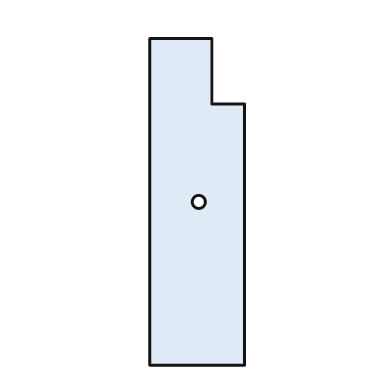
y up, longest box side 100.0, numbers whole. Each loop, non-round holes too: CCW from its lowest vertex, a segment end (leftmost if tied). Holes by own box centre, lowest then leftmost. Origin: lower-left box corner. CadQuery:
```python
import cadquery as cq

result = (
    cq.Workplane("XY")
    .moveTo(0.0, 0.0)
    .lineTo(29.0, 0.0)
    .lineTo(29.0, 80.0)
    .lineTo(19.0, 80.0)
    .lineTo(19.0, 100.0)
    .lineTo(0.0, 100.0)
    .close()
    .moveTo(15.0, 50.0)
    .circle(2.0)
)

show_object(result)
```